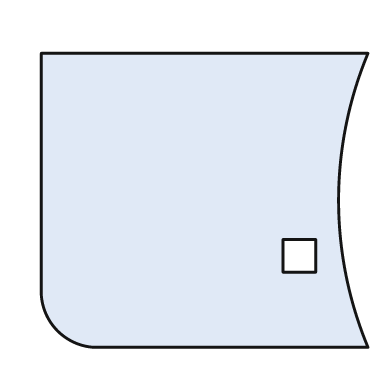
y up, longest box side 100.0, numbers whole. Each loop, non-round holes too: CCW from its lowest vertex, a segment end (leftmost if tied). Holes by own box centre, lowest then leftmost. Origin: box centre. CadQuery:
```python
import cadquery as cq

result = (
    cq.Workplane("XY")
    .moveTo(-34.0, -45.0)
    .lineTo(50.0, -45.0)
    .threePointArc((41.0, 0.0), (50.0, 45.0))
    .lineTo(-50.0, 45.0)
    .lineTo(-50.0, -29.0)
    .threePointArc((-45.0, -40.0), (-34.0, -45.0))
    .close()
    .moveTo(24.0, -22.0)
    .lineTo(34.0, -22.0)
    .lineTo(34.0, -12.0)
    .lineTo(24.0, -12.0)
    .close()
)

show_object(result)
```